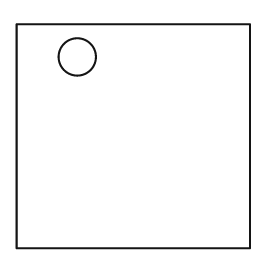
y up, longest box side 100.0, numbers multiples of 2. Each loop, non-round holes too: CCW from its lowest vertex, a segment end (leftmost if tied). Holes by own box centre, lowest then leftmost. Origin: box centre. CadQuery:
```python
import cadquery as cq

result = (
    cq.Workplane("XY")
    .moveTo(-50.0, -48.0)
    .lineTo(50.0, -48.0)
    .lineTo(50.0, 48.0)
    .lineTo(-50.0, 48.0)
    .close()
    .moveTo(-24.0, 34.0)
    .circle(8.0)
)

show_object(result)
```